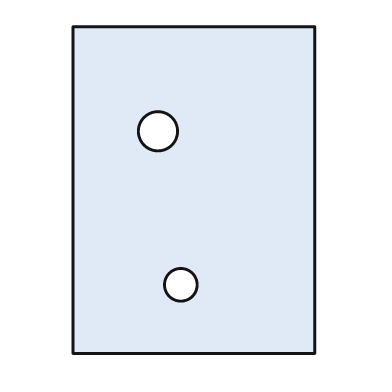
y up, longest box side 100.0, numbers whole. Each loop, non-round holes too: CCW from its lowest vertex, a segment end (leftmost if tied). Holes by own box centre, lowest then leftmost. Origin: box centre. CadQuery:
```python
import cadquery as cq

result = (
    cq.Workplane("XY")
    .moveTo(-37.0, -50.0)
    .lineTo(37.0, -50.0)
    .lineTo(37.0, 50.0)
    .lineTo(-37.0, 50.0)
    .close()
    .moveTo(-4.0, -29.0)
    .circle(5.0)
    .moveTo(-11.0, 18.0)
    .circle(6.0)
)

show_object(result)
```